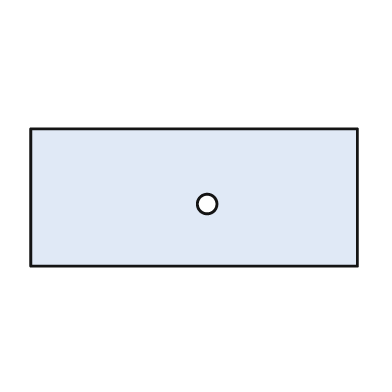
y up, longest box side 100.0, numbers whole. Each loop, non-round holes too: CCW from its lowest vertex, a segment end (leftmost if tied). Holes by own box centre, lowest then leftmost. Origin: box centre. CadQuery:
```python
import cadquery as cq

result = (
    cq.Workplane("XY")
    .moveTo(-50.0, -21.0)
    .lineTo(50.0, -21.0)
    .lineTo(50.0, 21.0)
    .lineTo(-50.0, 21.0)
    .close()
    .moveTo(4.0, -2.0)
    .circle(3.0)
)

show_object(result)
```